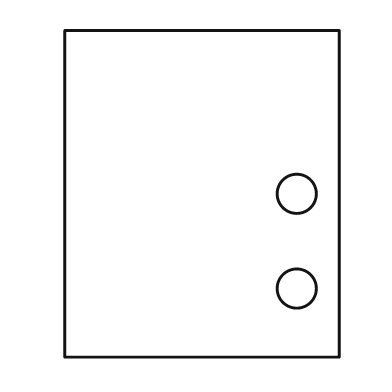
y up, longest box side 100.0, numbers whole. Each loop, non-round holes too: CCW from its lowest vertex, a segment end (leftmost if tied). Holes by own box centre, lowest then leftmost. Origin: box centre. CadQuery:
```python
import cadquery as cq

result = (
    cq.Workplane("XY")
    .moveTo(-42.0, -50.0)
    .lineTo(42.0, -50.0)
    .lineTo(42.0, 50.0)
    .lineTo(-42.0, 50.0)
    .close()
    .moveTo(29.0, -29.0)
    .circle(6.0)
    .moveTo(29.0, 0.0)
    .circle(6.0)
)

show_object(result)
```